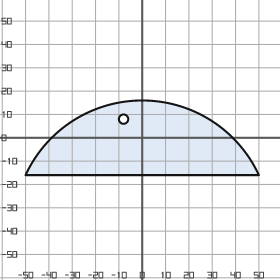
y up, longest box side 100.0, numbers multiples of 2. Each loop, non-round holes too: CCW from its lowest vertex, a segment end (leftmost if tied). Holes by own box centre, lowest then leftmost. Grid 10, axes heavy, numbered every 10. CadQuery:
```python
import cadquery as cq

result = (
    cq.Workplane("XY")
    .moveTo(-50.0, -16.0)
    .lineTo(50.0, -16.0)
    .threePointArc((0.0, 16.0), (-50.0, -16.0))
    .close()
    .moveTo(-8.0, 8.0)
    .circle(2.0)
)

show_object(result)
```